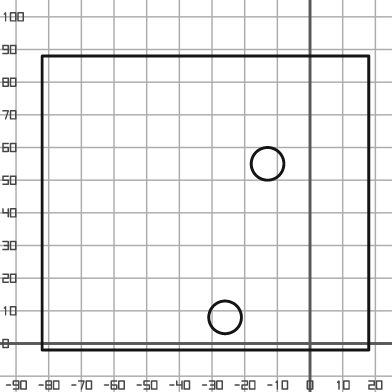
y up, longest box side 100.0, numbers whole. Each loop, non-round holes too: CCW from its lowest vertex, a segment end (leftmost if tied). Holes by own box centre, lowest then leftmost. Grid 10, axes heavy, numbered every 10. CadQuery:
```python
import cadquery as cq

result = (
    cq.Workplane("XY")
    .moveTo(-82.0, -2.0)
    .lineTo(18.0, -2.0)
    .lineTo(18.0, 88.0)
    .lineTo(-82.0, 88.0)
    .close()
    .moveTo(-26.0, 8.0)
    .circle(5.0)
    .moveTo(-13.0, 55.0)
    .circle(5.0)
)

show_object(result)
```